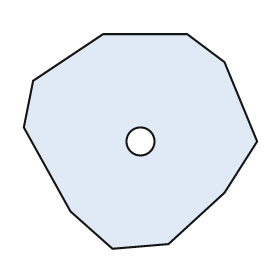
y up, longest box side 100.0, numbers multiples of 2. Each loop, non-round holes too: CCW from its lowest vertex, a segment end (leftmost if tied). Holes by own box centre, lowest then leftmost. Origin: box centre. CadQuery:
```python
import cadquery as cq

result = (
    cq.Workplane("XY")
    .moveTo(-12.0, -46.0)
    .lineTo(12.0, -44.0)
    .lineTo(36.0, -22.0)
    .lineTo(50.0, 0.0)
    .lineTo(36.0, 34.0)
    .lineTo(20.0, 46.0)
    .lineTo(-16.0, 46.0)
    .lineTo(-46.0, 26.0)
    .lineTo(-50.0, 6.0)
    .lineTo(-30.0, -30.0)
    .close()
    .moveTo(0.0, 0.0)
    .circle(6.0)
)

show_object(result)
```